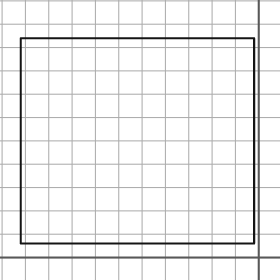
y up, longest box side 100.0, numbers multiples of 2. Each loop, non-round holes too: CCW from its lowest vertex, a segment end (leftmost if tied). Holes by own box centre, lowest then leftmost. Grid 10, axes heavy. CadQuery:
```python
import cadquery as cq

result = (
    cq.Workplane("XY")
    .moveTo(-102.0, 6.0)
    .lineTo(-2.0, 6.0)
    .lineTo(-2.0, 94.0)
    .lineTo(-102.0, 94.0)
    .close()
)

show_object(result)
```